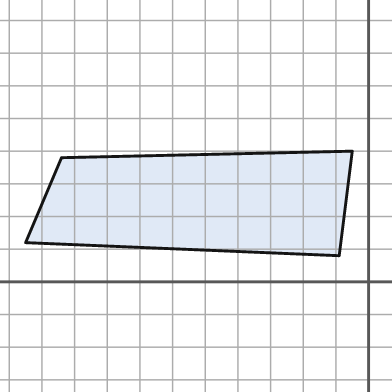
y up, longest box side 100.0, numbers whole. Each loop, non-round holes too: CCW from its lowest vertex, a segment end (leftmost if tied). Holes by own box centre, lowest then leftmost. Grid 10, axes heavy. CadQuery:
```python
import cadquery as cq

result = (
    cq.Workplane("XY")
    .moveTo(-9.0, 8.0)
    .lineTo(-5.0, 40.0)
    .lineTo(-94.0, 38.0)
    .lineTo(-105.0, 12.0)
    .close()
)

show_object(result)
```